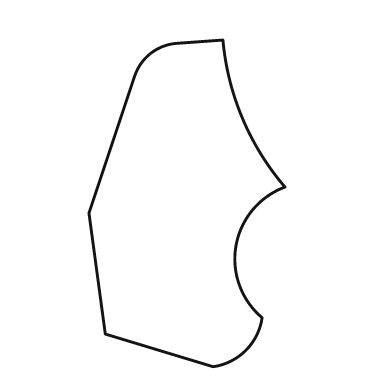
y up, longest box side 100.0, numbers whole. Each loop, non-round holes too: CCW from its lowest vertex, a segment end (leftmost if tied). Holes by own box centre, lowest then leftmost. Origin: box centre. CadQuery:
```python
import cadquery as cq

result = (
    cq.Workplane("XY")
    .moveTo(8.0, -50.0)
    .threePointArc((18.0, -45.0), (23.0, -35.0))
    .threePointArc((15.0, -13.0), (30.0, 5.0))
    .threePointArc((17.0, 26.0), (11.0, 50.0))
    .lineTo(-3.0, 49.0)
    .threePointArc((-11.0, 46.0), (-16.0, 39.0))
    .lineTo(-30.0, -3.0)
    .lineTo(-25.0, -40.0)
    .close()
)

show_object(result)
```